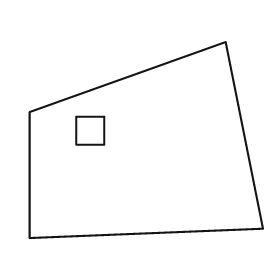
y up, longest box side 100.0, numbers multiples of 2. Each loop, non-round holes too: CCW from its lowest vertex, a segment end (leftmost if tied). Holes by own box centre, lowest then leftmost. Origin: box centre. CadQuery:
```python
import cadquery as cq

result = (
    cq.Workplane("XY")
    .moveTo(-50.0, -42.0)
    .lineTo(50.0, -38.0)
    .lineTo(34.0, 42.0)
    .lineTo(-50.0, 12.0)
    .close()
    .moveTo(-30.0, -2.0)
    .lineTo(-18.0, -2.0)
    .lineTo(-18.0, 10.0)
    .lineTo(-30.0, 10.0)
    .close()
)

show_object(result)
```